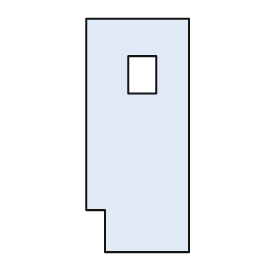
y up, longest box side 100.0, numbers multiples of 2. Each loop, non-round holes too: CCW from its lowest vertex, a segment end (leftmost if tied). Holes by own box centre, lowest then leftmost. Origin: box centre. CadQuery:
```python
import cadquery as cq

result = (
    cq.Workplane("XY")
    .moveTo(-14.0, -50.0)
    .lineTo(22.0, -50.0)
    .lineTo(22.0, 50.0)
    .lineTo(-22.0, 50.0)
    .lineTo(-22.0, -32.0)
    .lineTo(-14.0, -32.0)
    .close()
    .moveTo(-4.0, 18.0)
    .lineTo(8.0, 18.0)
    .lineTo(8.0, 34.0)
    .lineTo(-4.0, 34.0)
    .close()
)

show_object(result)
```